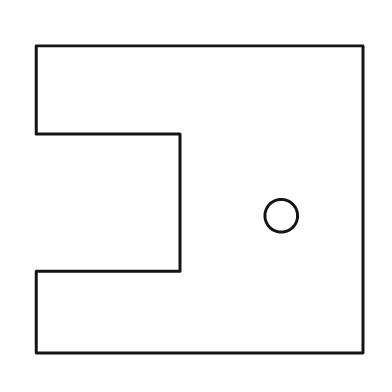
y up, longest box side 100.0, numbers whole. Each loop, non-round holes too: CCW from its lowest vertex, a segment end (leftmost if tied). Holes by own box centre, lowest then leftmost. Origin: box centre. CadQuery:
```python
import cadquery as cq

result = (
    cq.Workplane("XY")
    .moveTo(-50.0, -47.0)
    .lineTo(50.0, -47.0)
    .lineTo(50.0, 47.0)
    .lineTo(-50.0, 47.0)
    .lineTo(-50.0, 20.0)
    .lineTo(-6.0, 20.0)
    .lineTo(-6.0, -22.0)
    .lineTo(-50.0, -22.0)
    .close()
    .moveTo(25.0, -5.0)
    .circle(5.0)
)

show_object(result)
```